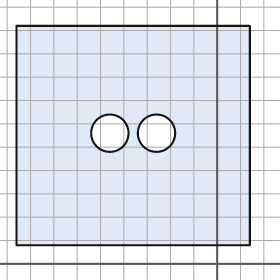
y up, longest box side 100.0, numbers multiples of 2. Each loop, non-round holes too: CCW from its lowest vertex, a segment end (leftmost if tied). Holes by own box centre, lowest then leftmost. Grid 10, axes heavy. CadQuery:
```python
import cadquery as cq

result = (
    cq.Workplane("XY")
    .moveTo(-86.0, 8.0)
    .lineTo(14.0, 8.0)
    .lineTo(14.0, 102.0)
    .lineTo(-86.0, 102.0)
    .close()
    .moveTo(-46.0, 56.0)
    .circle(8.0)
    .moveTo(-26.0, 56.0)
    .circle(8.0)
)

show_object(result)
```